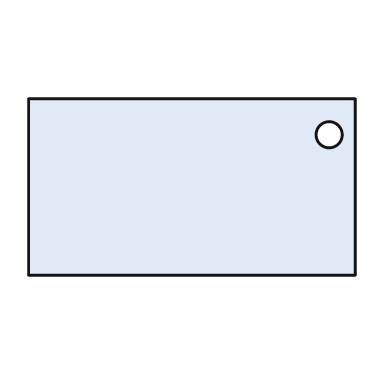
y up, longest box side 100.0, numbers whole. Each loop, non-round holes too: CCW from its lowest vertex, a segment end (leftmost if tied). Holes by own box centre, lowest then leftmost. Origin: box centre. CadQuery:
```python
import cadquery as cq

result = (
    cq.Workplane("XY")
    .moveTo(-50.0, -27.0)
    .lineTo(50.0, -27.0)
    .lineTo(50.0, 27.0)
    .lineTo(-50.0, 27.0)
    .close()
    .moveTo(42.0, 16.0)
    .circle(4.0)
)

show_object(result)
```